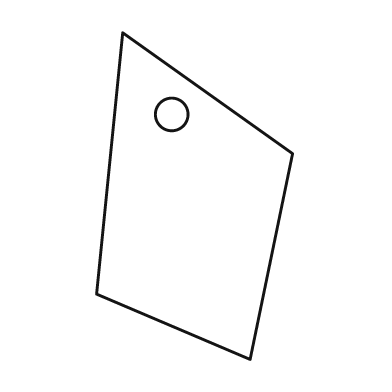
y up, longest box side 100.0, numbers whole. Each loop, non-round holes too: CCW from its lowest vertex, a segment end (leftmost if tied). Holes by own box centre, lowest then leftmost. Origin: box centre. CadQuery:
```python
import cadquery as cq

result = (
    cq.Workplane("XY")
    .moveTo(17.0, -50.0)
    .lineTo(30.0, 13.0)
    .lineTo(-22.0, 50.0)
    .lineTo(-30.0, -30.0)
    .close()
    .moveTo(-7.0, 25.0)
    .circle(5.0)
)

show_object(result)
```